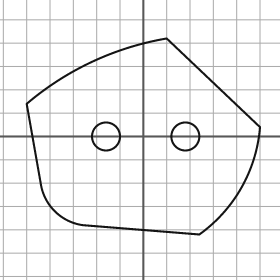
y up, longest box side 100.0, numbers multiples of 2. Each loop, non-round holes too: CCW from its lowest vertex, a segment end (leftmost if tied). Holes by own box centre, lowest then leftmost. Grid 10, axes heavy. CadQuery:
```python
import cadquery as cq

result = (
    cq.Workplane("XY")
    .moveTo(24.0, -42.0)
    .threePointArc((42.0, -22.0), (50.0, 4.0))
    .lineTo(10.0, 42.0)
    .threePointArc((-22.0, 32.0), (-50.0, 14.0))
    .lineTo(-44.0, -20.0)
    .threePointArc((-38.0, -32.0), (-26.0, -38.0))
    .close()
    .moveTo(-16.0, 0.0)
    .circle(6.0)
    .moveTo(18.0, 0.0)
    .circle(6.0)
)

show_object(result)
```